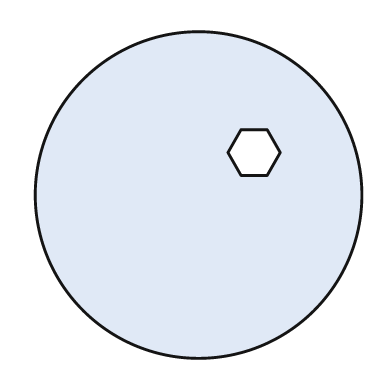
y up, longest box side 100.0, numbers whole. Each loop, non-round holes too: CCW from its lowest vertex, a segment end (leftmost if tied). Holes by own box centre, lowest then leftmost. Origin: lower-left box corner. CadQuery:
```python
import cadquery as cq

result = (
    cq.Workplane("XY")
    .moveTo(50.0, 50.0)
    .circle(50.0)
    .moveTo(63.0, 56.0)
    .lineTo(71.0, 56.0)
    .lineTo(75.0, 63.0)
    .lineTo(71.0, 70.0)
    .lineTo(63.0, 70.0)
    .lineTo(59.0, 63.0)
    .close()
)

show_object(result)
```